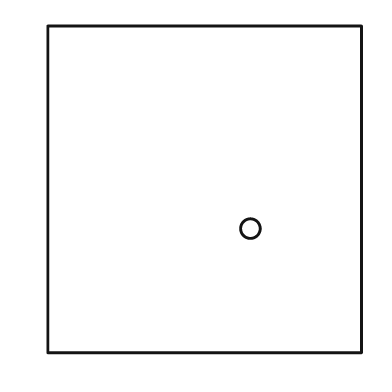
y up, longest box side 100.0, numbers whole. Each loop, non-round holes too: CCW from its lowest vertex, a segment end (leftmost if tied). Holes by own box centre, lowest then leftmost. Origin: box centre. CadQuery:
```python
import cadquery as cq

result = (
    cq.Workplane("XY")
    .moveTo(-48.0, -50.0)
    .lineTo(48.0, -50.0)
    .lineTo(48.0, 50.0)
    .lineTo(-48.0, 50.0)
    .close()
    .moveTo(14.0, -12.0)
    .circle(3.0)
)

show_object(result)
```